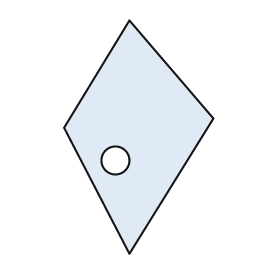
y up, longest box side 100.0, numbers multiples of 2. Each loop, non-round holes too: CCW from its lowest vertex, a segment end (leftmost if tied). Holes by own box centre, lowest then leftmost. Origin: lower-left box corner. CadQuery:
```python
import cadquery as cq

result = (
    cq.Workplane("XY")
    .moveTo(28.0, 0.0)
    .lineTo(64.0, 58.0)
    .lineTo(28.0, 100.0)
    .lineTo(0.0, 54.0)
    .close()
    .moveTo(22.0, 40.0)
    .circle(6.0)
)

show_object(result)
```